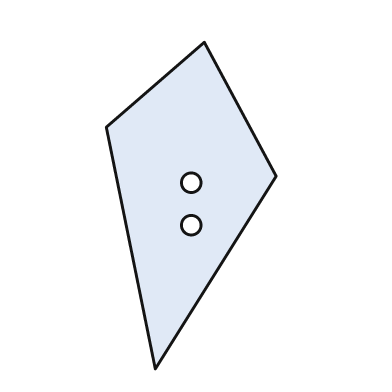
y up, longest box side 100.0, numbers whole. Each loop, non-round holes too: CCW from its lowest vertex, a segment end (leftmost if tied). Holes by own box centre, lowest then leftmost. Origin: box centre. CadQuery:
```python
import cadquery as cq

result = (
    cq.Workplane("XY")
    .moveTo(-11.0, -50.0)
    .lineTo(26.0, 9.0)
    .lineTo(4.0, 50.0)
    .lineTo(-26.0, 24.0)
    .close()
    .moveTo(0.0, -6.0)
    .circle(3.0)
    .moveTo(0.0, 7.0)
    .circle(3.0)
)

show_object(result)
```